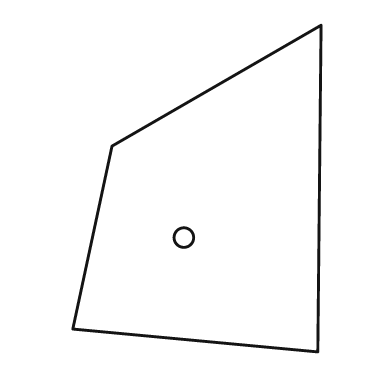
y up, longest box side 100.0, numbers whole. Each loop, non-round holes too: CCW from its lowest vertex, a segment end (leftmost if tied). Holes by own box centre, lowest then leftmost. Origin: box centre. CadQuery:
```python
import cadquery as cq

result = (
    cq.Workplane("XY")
    .moveTo(37.0, -50.0)
    .lineTo(38.0, 50.0)
    .lineTo(-26.0, 13.0)
    .lineTo(-38.0, -43.0)
    .close()
    .moveTo(-4.0, -15.0)
    .circle(3.0)
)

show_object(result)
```